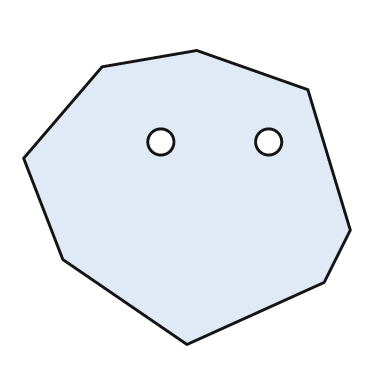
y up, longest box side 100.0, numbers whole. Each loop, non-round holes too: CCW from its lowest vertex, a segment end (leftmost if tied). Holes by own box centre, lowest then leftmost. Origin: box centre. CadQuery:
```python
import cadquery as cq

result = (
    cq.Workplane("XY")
    .moveTo(0.0, -45.0)
    .lineTo(42.0, -26.0)
    .lineTo(50.0, -10.0)
    .lineTo(37.0, 33.0)
    .lineTo(3.0, 45.0)
    .lineTo(-26.0, 40.0)
    .lineTo(-50.0, 12.0)
    .lineTo(-38.0, -19.0)
    .close()
    .moveTo(-8.0, 17.0)
    .circle(4.0)
    .moveTo(25.0, 17.0)
    .circle(4.0)
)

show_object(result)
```